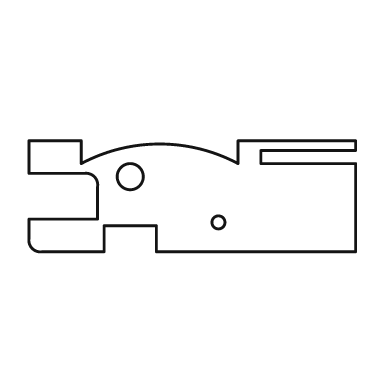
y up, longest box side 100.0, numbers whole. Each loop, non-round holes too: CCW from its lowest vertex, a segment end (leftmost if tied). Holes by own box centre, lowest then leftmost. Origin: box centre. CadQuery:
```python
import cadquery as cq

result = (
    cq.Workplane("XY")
    .moveTo(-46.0, -17.0)
    .lineTo(-27.0, -17.0)
    .lineTo(-27.0, -9.0)
    .lineTo(-11.0, -9.0)
    .lineTo(-11.0, -17.0)
    .lineTo(50.0, -17.0)
    .lineTo(50.0, 10.0)
    .lineTo(21.0, 10.0)
    .lineTo(21.0, 14.0)
    .lineTo(50.0, 14.0)
    .lineTo(50.0, 17.0)
    .lineTo(14.0, 17.0)
    .lineTo(14.0, 10.0)
    .threePointArc((-10.0, 16.0), (-34.0, 10.0))
    .lineTo(-34.0, 17.0)
    .lineTo(-50.0, 17.0)
    .lineTo(-50.0, 7.0)
    .lineTo(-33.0, 7.0)
    .threePointArc((-30.0, 6.0), (-29.0, 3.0))
    .lineTo(-29.0, -7.0)
    .lineTo(-50.0, -7.0)
    .lineTo(-50.0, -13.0)
    .threePointArc((-49.0, -16.0), (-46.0, -17.0))
    .close()
    .moveTo(8.0, -8.0)
    .circle(2.0)
    .moveTo(-19.0, 6.0)
    .circle(4.0)
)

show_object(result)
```